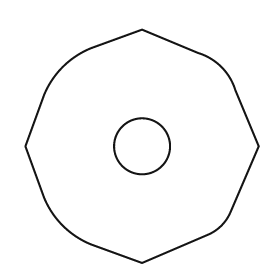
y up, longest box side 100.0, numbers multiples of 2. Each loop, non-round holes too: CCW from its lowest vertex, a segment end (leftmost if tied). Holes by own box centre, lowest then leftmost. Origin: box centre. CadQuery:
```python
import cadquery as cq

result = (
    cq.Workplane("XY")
    .moveTo(0.0, -50.0)
    .lineTo(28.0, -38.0)
    .threePointArc((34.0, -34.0), (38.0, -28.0))
    .lineTo(50.0, 0.0)
    .lineTo(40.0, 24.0)
    .threePointArc((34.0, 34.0), (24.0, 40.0))
    .lineTo(0.0, 50.0)
    .lineTo(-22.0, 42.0)
    .threePointArc((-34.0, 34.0), (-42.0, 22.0))
    .lineTo(-50.0, 0.0)
    .lineTo(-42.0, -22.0)
    .threePointArc((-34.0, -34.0), (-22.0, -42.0))
    .close()
    .moveTo(0.0, 0.0)
    .circle(12.0)
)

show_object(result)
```